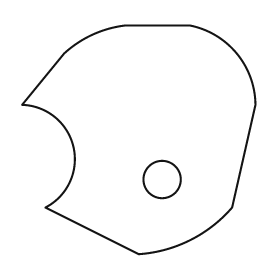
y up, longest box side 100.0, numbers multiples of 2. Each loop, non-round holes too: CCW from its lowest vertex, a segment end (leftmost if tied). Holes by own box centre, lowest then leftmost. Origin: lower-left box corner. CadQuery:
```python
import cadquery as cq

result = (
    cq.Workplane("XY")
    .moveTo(50.0, 0.0)
    .threePointArc((72.0, 6.0), (90.0, 20.0))
    .lineTo(100.0, 64.0)
    .threePointArc((92.0, 86.0), (72.0, 98.0))
    .lineTo(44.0, 98.0)
    .threePointArc((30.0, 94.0), (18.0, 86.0))
    .lineTo(0.0, 64.0)
    .threePointArc((22.0, 46.0), (10.0, 20.0))
    .close()
    .moveTo(60.0, 32.0)
    .circle(8.0)
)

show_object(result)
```